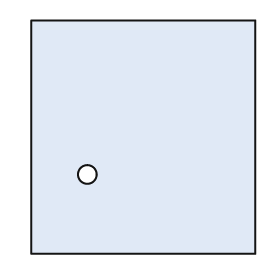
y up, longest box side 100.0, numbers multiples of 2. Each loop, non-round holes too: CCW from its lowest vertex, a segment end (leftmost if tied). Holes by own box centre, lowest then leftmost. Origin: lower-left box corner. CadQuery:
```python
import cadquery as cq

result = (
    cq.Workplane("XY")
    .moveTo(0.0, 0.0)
    .lineTo(96.0, 0.0)
    .lineTo(96.0, 100.0)
    .lineTo(0.0, 100.0)
    .close()
    .moveTo(24.0, 34.0)
    .circle(4.0)
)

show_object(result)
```